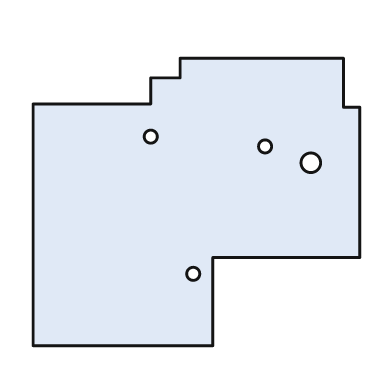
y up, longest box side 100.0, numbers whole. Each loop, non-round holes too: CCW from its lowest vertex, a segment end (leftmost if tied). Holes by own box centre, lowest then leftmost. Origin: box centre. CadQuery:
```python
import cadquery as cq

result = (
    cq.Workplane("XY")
    .moveTo(-50.0, -44.0)
    .lineTo(5.0, -44.0)
    .lineTo(5.0, -17.0)
    .lineTo(50.0, -17.0)
    .lineTo(50.0, 29.0)
    .lineTo(45.0, 29.0)
    .lineTo(45.0, 44.0)
    .lineTo(-5.0, 44.0)
    .lineTo(-5.0, 38.0)
    .lineTo(-14.0, 38.0)
    .lineTo(-14.0, 30.0)
    .lineTo(-50.0, 30.0)
    .close()
    .moveTo(-1.0, -22.0)
    .circle(2.0)
    .moveTo(35.0, 12.0)
    .circle(3.0)
    .moveTo(21.0, 17.0)
    .circle(2.0)
    .moveTo(-14.0, 20.0)
    .circle(2.0)
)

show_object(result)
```